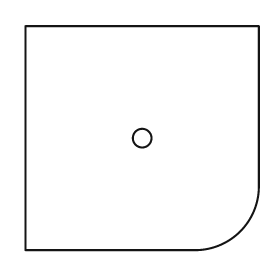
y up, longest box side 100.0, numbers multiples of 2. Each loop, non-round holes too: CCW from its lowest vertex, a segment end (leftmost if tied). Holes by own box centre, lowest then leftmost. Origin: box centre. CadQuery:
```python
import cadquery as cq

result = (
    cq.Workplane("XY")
    .moveTo(-50.0, -48.0)
    .lineTo(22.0, -48.0)
    .threePointArc((42.0, -40.0), (50.0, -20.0))
    .lineTo(50.0, 48.0)
    .lineTo(-50.0, 48.0)
    .close()
    .moveTo(0.0, 0.0)
    .circle(4.0)
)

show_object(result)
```